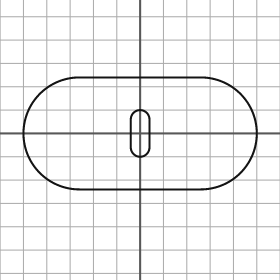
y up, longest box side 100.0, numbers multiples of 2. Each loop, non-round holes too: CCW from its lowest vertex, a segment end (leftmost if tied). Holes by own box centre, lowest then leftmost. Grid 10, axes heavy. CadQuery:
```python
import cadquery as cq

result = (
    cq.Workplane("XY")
    .moveTo(-26.0, -24.0)
    .lineTo(26.0, -24.0)
    .threePointArc((50.0, 0.0), (26.0, 24.0))
    .lineTo(-26.0, 24.0)
    .threePointArc((-50.0, 0.0), (-26.0, -24.0))
    .close()
    .moveTo(-4.0, -6.0)
    .threePointArc((0.0, -10.0), (4.0, -6.0))
    .lineTo(4.0, 6.0)
    .threePointArc((0.0, 10.0), (-4.0, 6.0))
    .close()
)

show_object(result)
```